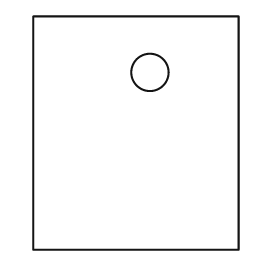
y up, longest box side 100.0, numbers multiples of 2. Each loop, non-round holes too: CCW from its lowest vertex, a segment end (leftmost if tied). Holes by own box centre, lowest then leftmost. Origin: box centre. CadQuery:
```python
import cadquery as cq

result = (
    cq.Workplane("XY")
    .moveTo(-44.0, -50.0)
    .lineTo(44.0, -50.0)
    .lineTo(44.0, 50.0)
    .lineTo(-44.0, 50.0)
    .close()
    .moveTo(6.0, 26.0)
    .circle(8.0)
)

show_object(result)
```